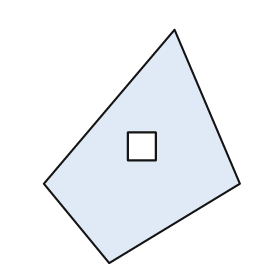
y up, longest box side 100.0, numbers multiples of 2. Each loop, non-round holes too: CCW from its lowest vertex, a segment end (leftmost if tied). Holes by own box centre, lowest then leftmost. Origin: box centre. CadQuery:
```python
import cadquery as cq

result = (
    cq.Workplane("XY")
    .moveTo(-14.0, -50.0)
    .lineTo(42.0, -16.0)
    .lineTo(14.0, 50.0)
    .lineTo(-42.0, -16.0)
    .close()
    .moveTo(-6.0, -6.0)
    .lineTo(6.0, -6.0)
    .lineTo(6.0, 6.0)
    .lineTo(-6.0, 6.0)
    .close()
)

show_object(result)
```